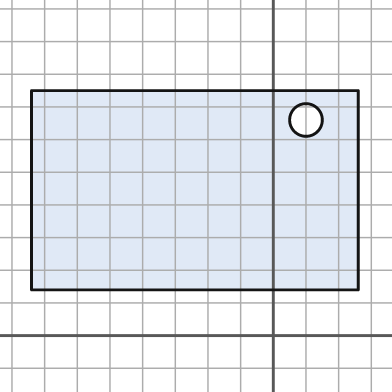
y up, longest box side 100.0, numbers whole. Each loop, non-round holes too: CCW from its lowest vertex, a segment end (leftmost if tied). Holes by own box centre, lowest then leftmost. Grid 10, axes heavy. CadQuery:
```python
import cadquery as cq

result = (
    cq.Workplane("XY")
    .moveTo(-74.0, 14.0)
    .lineTo(26.0, 14.0)
    .lineTo(26.0, 75.0)
    .lineTo(-74.0, 75.0)
    .close()
    .moveTo(10.0, 66.0)
    .circle(5.0)
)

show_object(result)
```